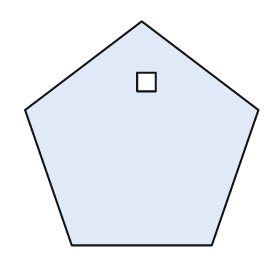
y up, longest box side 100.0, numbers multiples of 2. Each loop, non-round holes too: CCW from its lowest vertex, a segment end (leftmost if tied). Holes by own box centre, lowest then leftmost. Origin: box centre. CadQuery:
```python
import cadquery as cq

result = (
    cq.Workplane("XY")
    .moveTo(-30.0, -48.0)
    .lineTo(30.0, -48.0)
    .lineTo(50.0, 10.0)
    .lineTo(0.0, 48.0)
    .lineTo(-50.0, 10.0)
    .close()
    .moveTo(-2.0, 18.0)
    .lineTo(6.0, 18.0)
    .lineTo(6.0, 26.0)
    .lineTo(-2.0, 26.0)
    .close()
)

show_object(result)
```